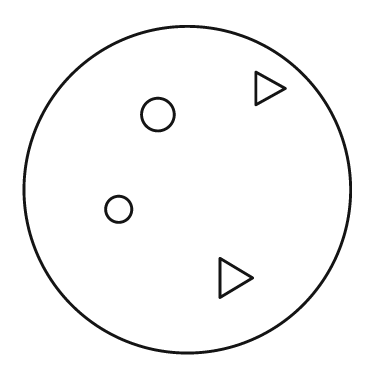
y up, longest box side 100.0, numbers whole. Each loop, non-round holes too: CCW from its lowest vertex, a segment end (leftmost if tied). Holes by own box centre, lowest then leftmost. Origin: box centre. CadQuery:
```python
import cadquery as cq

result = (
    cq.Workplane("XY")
    .moveTo(0.0, 0.0)
    .circle(50.0)
    .moveTo(10.0, -33.0)
    .lineTo(20.0, -27.0)
    .lineTo(10.0, -21.0)
    .close()
    .moveTo(-21.0, -6.0)
    .circle(4.0)
    .moveTo(-9.0, 23.0)
    .circle(5.0)
    .moveTo(21.0, 26.0)
    .lineTo(30.0, 31.0)
    .lineTo(21.0, 36.0)
    .close()
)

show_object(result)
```